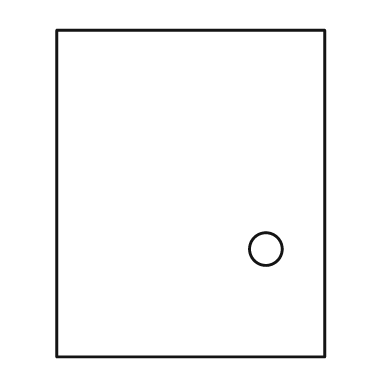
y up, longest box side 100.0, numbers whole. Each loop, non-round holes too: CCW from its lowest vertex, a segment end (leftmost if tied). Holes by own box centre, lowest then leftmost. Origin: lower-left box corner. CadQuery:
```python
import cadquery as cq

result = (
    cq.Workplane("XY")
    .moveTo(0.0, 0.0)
    .lineTo(82.0, 0.0)
    .lineTo(82.0, 100.0)
    .lineTo(0.0, 100.0)
    .close()
    .moveTo(64.0, 33.0)
    .circle(5.0)
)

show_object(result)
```